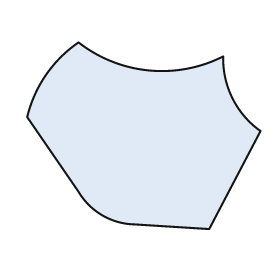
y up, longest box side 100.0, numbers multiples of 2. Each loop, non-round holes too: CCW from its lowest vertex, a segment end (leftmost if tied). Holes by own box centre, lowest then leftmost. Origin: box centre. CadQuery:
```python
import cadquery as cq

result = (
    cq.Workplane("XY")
    .moveTo(28.0, -40.0)
    .lineTo(50.0, 2.0)
    .threePointArc((38.0, 16.0), (34.0, 34.0))
    .threePointArc((2.0, 28.0), (-28.0, 40.0))
    .threePointArc((-42.0, 26.0), (-50.0, 8.0))
    .lineTo(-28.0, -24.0)
    .threePointArc((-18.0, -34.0), (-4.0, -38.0))
    .close()
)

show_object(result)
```